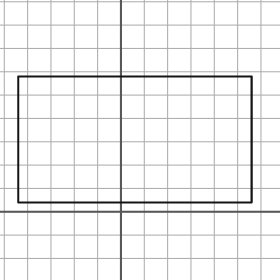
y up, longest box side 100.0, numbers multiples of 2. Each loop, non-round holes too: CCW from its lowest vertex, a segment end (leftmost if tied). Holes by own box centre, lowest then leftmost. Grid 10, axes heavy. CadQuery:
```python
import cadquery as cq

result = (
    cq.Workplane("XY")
    .moveTo(-44.0, 4.0)
    .lineTo(56.0, 4.0)
    .lineTo(56.0, 58.0)
    .lineTo(-44.0, 58.0)
    .close()
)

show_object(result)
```